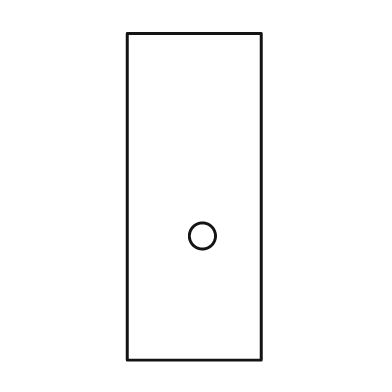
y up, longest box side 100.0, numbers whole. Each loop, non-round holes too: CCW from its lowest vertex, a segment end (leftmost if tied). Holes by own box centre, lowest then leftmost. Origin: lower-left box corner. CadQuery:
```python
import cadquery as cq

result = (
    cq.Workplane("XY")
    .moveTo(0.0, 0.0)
    .lineTo(41.0, 0.0)
    .lineTo(41.0, 100.0)
    .lineTo(0.0, 100.0)
    .close()
    .moveTo(23.0, 38.0)
    .circle(4.0)
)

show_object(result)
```